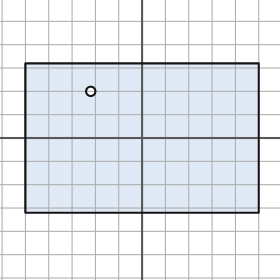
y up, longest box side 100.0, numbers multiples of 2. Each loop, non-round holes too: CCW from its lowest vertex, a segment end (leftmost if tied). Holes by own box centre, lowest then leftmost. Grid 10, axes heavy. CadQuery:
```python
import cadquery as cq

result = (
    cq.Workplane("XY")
    .moveTo(-50.0, -32.0)
    .lineTo(50.0, -32.0)
    .lineTo(50.0, 32.0)
    .lineTo(-50.0, 32.0)
    .close()
    .moveTo(-22.0, 20.0)
    .circle(2.0)
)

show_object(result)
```